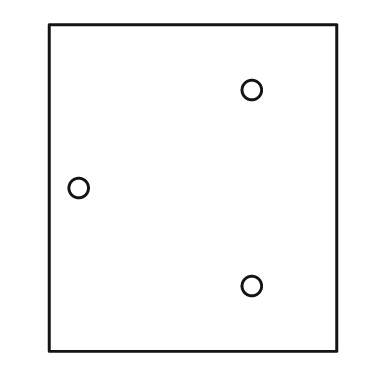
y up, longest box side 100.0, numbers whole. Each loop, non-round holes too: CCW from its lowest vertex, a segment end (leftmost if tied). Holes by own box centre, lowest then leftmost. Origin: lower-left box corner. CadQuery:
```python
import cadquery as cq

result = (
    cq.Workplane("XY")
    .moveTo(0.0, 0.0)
    .lineTo(88.0, 0.0)
    .lineTo(88.0, 100.0)
    .lineTo(0.0, 100.0)
    .close()
    .moveTo(62.0, 20.0)
    .circle(3.0)
    .moveTo(9.0, 50.0)
    .circle(3.0)
    .moveTo(62.0, 80.0)
    .circle(3.0)
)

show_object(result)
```